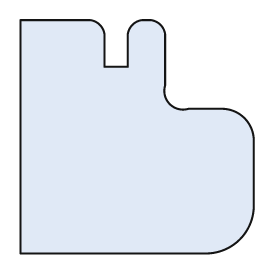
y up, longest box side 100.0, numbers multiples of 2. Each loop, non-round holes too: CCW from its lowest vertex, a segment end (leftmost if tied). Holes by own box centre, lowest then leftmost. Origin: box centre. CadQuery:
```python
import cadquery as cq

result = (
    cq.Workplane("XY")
    .moveTo(-50.0, -50.0)
    .lineTo(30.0, -50.0)
    .threePointArc((44.0, -44.0), (50.0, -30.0))
    .lineTo(50.0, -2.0)
    .threePointArc((46.0, 8.0), (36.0, 12.0))
    .lineTo(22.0, 12.0)
    .threePointArc((14.0, 14.0), (12.0, 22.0))
    .lineTo(12.0, 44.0)
    .threePointArc((10.0, 48.0), (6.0, 50.0))
    .lineTo(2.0, 50.0)
    .threePointArc((-2.0, 48.0), (-4.0, 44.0))
    .lineTo(-4.0, 30.0)
    .lineTo(-14.0, 30.0)
    .lineTo(-14.0, 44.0)
    .threePointArc((-16.0, 48.0), (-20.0, 50.0))
    .lineTo(-50.0, 50.0)
    .close()
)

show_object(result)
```